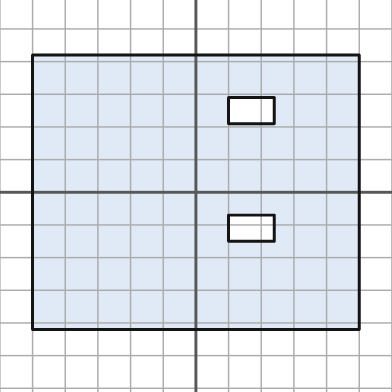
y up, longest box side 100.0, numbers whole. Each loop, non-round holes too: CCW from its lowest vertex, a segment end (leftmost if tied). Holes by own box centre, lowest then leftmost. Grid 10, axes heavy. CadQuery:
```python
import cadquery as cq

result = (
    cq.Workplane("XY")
    .moveTo(-50.0, -42.0)
    .lineTo(50.0, -42.0)
    .lineTo(50.0, 42.0)
    .lineTo(-50.0, 42.0)
    .close()
    .moveTo(10.0, -15.0)
    .lineTo(24.0, -15.0)
    .lineTo(24.0, -7.0)
    .lineTo(10.0, -7.0)
    .close()
    .moveTo(10.0, 21.0)
    .lineTo(24.0, 21.0)
    .lineTo(24.0, 29.0)
    .lineTo(10.0, 29.0)
    .close()
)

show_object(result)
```